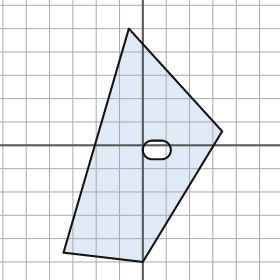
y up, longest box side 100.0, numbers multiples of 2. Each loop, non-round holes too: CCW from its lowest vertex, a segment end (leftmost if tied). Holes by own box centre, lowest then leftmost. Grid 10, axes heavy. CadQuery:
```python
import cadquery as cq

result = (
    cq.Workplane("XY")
    .moveTo(0.0, -50.0)
    .lineTo(34.0, 6.0)
    .lineTo(-6.0, 50.0)
    .lineTo(-34.0, -46.0)
    .close()
    .moveTo(4.0, -6.0)
    .lineTo(8.0, -6.0)
    .threePointArc((12.0, -2.0), (8.0, 2.0))
    .lineTo(4.0, 2.0)
    .threePointArc((0.0, -2.0), (4.0, -6.0))
    .close()
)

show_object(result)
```